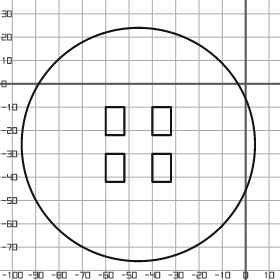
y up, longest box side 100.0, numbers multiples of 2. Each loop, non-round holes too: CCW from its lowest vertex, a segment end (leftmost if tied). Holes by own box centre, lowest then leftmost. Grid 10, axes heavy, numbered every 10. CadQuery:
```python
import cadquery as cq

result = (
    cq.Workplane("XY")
    .moveTo(-46.0, -26.0)
    .circle(50.0)
    .moveTo(-60.0, -42.0)
    .lineTo(-52.0, -42.0)
    .lineTo(-52.0, -30.0)
    .lineTo(-60.0, -30.0)
    .close()
    .moveTo(-40.0, -42.0)
    .lineTo(-32.0, -42.0)
    .lineTo(-32.0, -30.0)
    .lineTo(-40.0, -30.0)
    .close()
    .moveTo(-60.0, -22.0)
    .lineTo(-52.0, -22.0)
    .lineTo(-52.0, -10.0)
    .lineTo(-60.0, -10.0)
    .close()
    .moveTo(-40.0, -22.0)
    .lineTo(-32.0, -22.0)
    .lineTo(-32.0, -10.0)
    .lineTo(-40.0, -10.0)
    .close()
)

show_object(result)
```